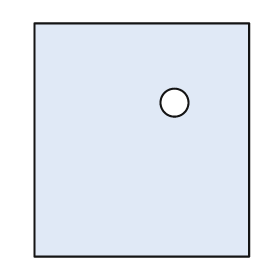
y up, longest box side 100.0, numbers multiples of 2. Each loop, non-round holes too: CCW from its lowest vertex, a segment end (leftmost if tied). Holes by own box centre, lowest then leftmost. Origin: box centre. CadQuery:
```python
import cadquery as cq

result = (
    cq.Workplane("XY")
    .moveTo(-46.0, -50.0)
    .lineTo(46.0, -50.0)
    .lineTo(46.0, 50.0)
    .lineTo(-46.0, 50.0)
    .close()
    .moveTo(14.0, 16.0)
    .circle(6.0)
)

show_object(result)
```